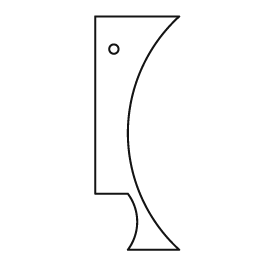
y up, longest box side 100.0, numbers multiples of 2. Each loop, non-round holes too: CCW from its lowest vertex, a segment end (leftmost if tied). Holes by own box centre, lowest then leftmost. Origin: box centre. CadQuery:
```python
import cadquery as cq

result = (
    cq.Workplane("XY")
    .moveTo(-4.0, -50.0)
    .lineTo(18.0, -50.0)
    .threePointArc((-4.0, 0.0), (18.0, 50.0))
    .lineTo(-18.0, 50.0)
    .lineTo(-18.0, -26.0)
    .lineTo(-4.0, -26.0)
    .threePointArc((0.0, -38.0), (-4.0, -50.0))
    .close()
    .moveTo(-10.0, 36.0)
    .circle(2.0)
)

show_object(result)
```